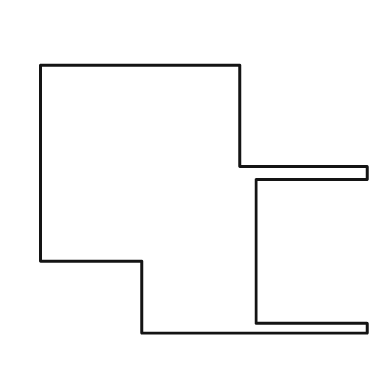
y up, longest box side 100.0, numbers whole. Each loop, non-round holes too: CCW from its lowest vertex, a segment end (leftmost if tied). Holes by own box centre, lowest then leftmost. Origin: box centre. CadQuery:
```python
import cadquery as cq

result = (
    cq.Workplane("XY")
    .moveTo(-19.0, -41.0)
    .lineTo(50.0, -41.0)
    .lineTo(50.0, -38.0)
    .lineTo(16.0, -38.0)
    .lineTo(16.0, 6.0)
    .lineTo(50.0, 6.0)
    .lineTo(50.0, 10.0)
    .lineTo(11.0, 10.0)
    .lineTo(11.0, 41.0)
    .lineTo(-50.0, 41.0)
    .lineTo(-50.0, -19.0)
    .lineTo(-19.0, -19.0)
    .close()
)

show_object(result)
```